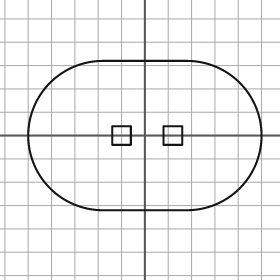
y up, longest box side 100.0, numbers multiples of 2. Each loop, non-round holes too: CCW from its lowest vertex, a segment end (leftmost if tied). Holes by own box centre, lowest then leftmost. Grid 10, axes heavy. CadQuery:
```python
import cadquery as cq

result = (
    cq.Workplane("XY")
    .moveTo(-18.0, -32.0)
    .lineTo(18.0, -32.0)
    .threePointArc((50.0, 0.0), (18.0, 32.0))
    .lineTo(-18.0, 32.0)
    .threePointArc((-50.0, 0.0), (-18.0, -32.0))
    .close()
    .moveTo(-14.0, -4.0)
    .lineTo(-6.0, -4.0)
    .lineTo(-6.0, 4.0)
    .lineTo(-14.0, 4.0)
    .close()
    .moveTo(8.0, -4.0)
    .lineTo(16.0, -4.0)
    .lineTo(16.0, 4.0)
    .lineTo(8.0, 4.0)
    .close()
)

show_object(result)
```